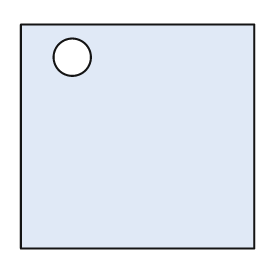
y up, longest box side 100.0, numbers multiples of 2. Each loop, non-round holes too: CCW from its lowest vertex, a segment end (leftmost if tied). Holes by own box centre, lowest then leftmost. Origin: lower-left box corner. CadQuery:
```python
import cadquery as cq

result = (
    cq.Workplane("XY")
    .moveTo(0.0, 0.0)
    .lineTo(100.0, 0.0)
    .lineTo(100.0, 96.0)
    .lineTo(0.0, 96.0)
    .close()
    .moveTo(22.0, 82.0)
    .circle(8.0)
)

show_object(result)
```